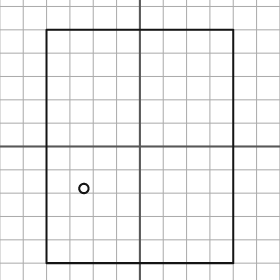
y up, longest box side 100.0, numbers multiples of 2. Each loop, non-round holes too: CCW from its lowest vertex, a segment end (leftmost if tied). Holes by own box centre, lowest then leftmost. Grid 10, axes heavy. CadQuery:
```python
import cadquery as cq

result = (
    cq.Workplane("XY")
    .moveTo(-40.0, -50.0)
    .lineTo(40.0, -50.0)
    .lineTo(40.0, 50.0)
    .lineTo(-40.0, 50.0)
    .close()
    .moveTo(-24.0, -18.0)
    .circle(2.0)
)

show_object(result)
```